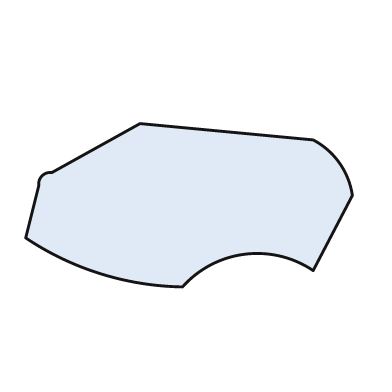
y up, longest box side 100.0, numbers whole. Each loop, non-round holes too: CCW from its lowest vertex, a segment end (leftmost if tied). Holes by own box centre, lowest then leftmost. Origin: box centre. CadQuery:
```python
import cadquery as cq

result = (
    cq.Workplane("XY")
    .moveTo(-2.0, -25.0)
    .threePointArc((17.0, -15.0), (38.0, -20.0))
    .lineTo(50.0, 3.0)
    .threePointArc((46.0, 13.0), (38.0, 20.0))
    .lineTo(-15.0, 25.0)
    .lineTo(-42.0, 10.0)
    .threePointArc((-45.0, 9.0), (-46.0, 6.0))
    .lineTo(-50.0, -10.0)
    .threePointArc((-27.0, -21.0), (-2.0, -25.0))
    .close()
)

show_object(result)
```